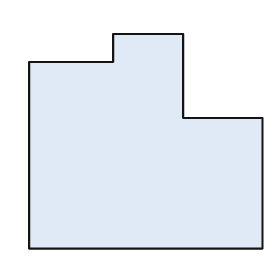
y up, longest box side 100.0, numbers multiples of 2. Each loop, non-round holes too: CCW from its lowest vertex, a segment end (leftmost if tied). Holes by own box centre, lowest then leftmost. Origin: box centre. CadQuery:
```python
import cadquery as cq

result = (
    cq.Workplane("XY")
    .moveTo(-50.0, -46.0)
    .lineTo(50.0, -46.0)
    .lineTo(50.0, 10.0)
    .lineTo(16.0, 10.0)
    .lineTo(16.0, 46.0)
    .lineTo(-14.0, 46.0)
    .lineTo(-14.0, 34.0)
    .lineTo(-50.0, 34.0)
    .close()
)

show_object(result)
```